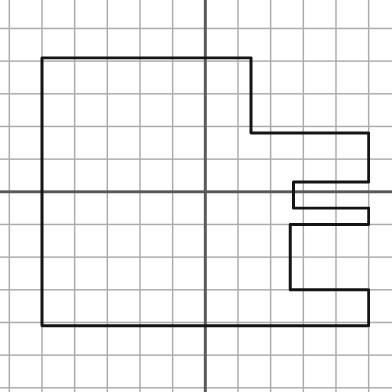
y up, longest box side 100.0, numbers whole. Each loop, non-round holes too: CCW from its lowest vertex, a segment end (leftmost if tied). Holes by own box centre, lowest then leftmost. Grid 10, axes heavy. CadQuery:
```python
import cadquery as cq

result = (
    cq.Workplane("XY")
    .moveTo(-50.0, -41.0)
    .lineTo(50.0, -41.0)
    .lineTo(50.0, -30.0)
    .lineTo(26.0, -30.0)
    .lineTo(26.0, -10.0)
    .lineTo(50.0, -10.0)
    .lineTo(50.0, -5.0)
    .lineTo(27.0, -5.0)
    .lineTo(27.0, 3.0)
    .lineTo(50.0, 3.0)
    .lineTo(50.0, 18.0)
    .lineTo(14.0, 18.0)
    .lineTo(14.0, 41.0)
    .lineTo(-50.0, 41.0)
    .close()
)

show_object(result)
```